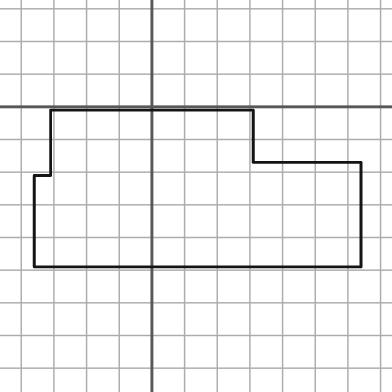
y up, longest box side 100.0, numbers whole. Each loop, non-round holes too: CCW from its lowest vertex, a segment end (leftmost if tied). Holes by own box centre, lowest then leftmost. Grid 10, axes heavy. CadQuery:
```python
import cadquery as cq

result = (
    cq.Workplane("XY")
    .moveTo(-36.0, -49.0)
    .lineTo(64.0, -49.0)
    .lineTo(64.0, -17.0)
    .lineTo(31.0, -17.0)
    .lineTo(31.0, -1.0)
    .lineTo(-31.0, -1.0)
    .lineTo(-31.0, -21.0)
    .lineTo(-36.0, -21.0)
    .close()
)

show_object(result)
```